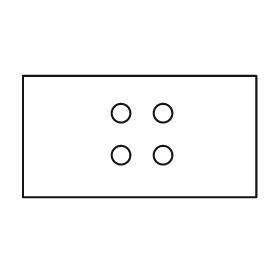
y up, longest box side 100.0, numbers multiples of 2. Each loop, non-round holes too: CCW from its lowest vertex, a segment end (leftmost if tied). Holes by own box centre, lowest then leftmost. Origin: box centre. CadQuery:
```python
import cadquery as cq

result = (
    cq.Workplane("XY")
    .moveTo(-50.0, -26.0)
    .lineTo(50.0, -26.0)
    .lineTo(50.0, 26.0)
    .lineTo(-50.0, 26.0)
    .close()
    .moveTo(-8.0, -8.0)
    .circle(4.0)
    .moveTo(10.0, -8.0)
    .circle(4.0)
    .moveTo(-8.0, 10.0)
    .circle(4.0)
    .moveTo(10.0, 10.0)
    .circle(4.0)
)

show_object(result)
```